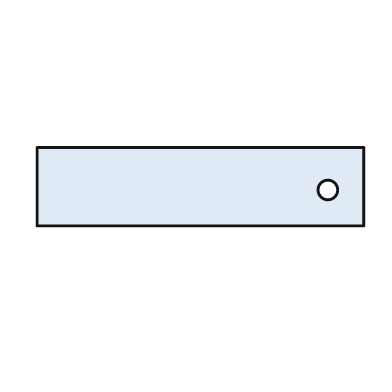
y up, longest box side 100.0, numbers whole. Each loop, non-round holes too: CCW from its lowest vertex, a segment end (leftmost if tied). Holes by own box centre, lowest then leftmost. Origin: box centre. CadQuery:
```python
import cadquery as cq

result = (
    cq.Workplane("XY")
    .moveTo(-50.0, -12.0)
    .lineTo(50.0, -12.0)
    .lineTo(50.0, 12.0)
    .lineTo(-50.0, 12.0)
    .close()
    .moveTo(39.0, -1.0)
    .circle(3.0)
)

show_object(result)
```